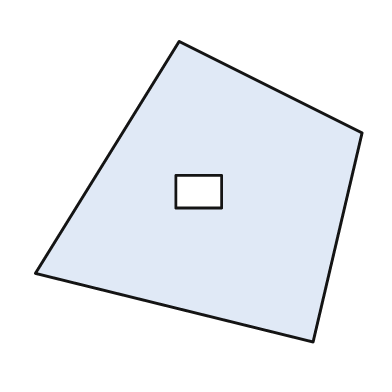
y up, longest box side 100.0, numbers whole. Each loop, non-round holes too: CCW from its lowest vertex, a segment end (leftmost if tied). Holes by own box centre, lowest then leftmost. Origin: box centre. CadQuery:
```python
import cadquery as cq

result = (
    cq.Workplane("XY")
    .moveTo(35.0, -46.0)
    .lineTo(50.0, 18.0)
    .lineTo(-6.0, 46.0)
    .lineTo(-50.0, -25.0)
    .close()
    .moveTo(-7.0, -5.0)
    .lineTo(7.0, -5.0)
    .lineTo(7.0, 5.0)
    .lineTo(-7.0, 5.0)
    .close()
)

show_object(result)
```